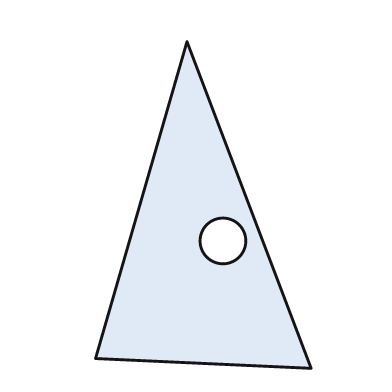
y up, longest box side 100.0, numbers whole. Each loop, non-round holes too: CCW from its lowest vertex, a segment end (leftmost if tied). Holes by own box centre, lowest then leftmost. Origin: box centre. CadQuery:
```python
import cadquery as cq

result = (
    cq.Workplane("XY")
    .moveTo(33.0, -50.0)
    .lineTo(-5.0, 50.0)
    .lineTo(-33.0, -47.0)
    .close()
    .moveTo(6.0, -11.0)
    .circle(7.0)
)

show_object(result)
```